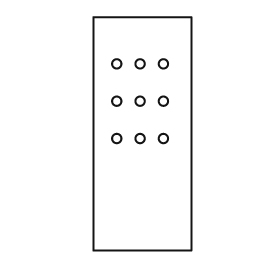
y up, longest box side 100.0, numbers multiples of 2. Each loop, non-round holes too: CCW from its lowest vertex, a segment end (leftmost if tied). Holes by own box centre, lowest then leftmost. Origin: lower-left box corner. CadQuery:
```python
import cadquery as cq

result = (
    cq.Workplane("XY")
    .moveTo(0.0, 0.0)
    .lineTo(42.0, 0.0)
    .lineTo(42.0, 100.0)
    .lineTo(0.0, 100.0)
    .close()
    .moveTo(10.0, 48.0)
    .circle(2.0)
    .moveTo(20.0, 48.0)
    .circle(2.0)
    .moveTo(30.0, 48.0)
    .circle(2.0)
    .moveTo(10.0, 64.0)
    .circle(2.0)
    .moveTo(20.0, 64.0)
    .circle(2.0)
    .moveTo(30.0, 64.0)
    .circle(2.0)
    .moveTo(10.0, 80.0)
    .circle(2.0)
    .moveTo(20.0, 80.0)
    .circle(2.0)
    .moveTo(30.0, 80.0)
    .circle(2.0)
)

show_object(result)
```